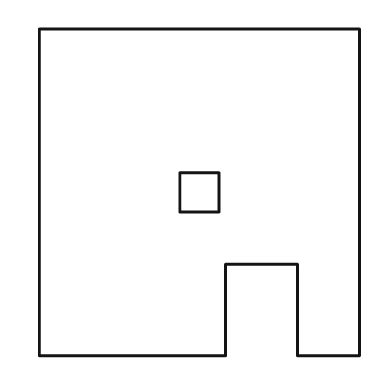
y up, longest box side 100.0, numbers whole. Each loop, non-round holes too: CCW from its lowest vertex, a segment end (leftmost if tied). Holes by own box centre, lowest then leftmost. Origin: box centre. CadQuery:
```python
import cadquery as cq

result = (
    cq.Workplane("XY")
    .moveTo(-49.0, -50.0)
    .lineTo(8.0, -50.0)
    .lineTo(8.0, -22.0)
    .lineTo(30.0, -22.0)
    .lineTo(30.0, -50.0)
    .lineTo(49.0, -50.0)
    .lineTo(49.0, 50.0)
    .lineTo(-49.0, 50.0)
    .close()
    .moveTo(-6.0, -6.0)
    .lineTo(6.0, -6.0)
    .lineTo(6.0, 6.0)
    .lineTo(-6.0, 6.0)
    .close()
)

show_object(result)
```